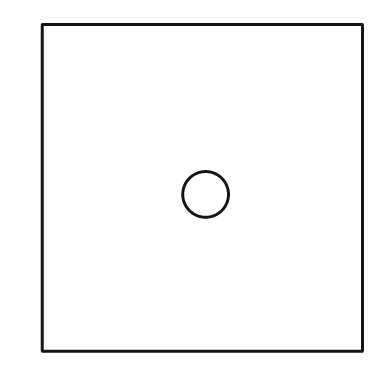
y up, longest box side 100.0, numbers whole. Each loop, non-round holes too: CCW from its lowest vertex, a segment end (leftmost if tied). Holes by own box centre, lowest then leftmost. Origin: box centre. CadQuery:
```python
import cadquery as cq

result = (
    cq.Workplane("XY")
    .moveTo(-49.0, -50.0)
    .lineTo(49.0, -50.0)
    .lineTo(49.0, 50.0)
    .lineTo(-49.0, 50.0)
    .close()
    .moveTo(1.0, -2.0)
    .circle(7.0)
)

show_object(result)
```